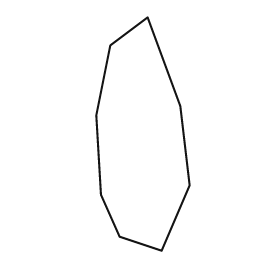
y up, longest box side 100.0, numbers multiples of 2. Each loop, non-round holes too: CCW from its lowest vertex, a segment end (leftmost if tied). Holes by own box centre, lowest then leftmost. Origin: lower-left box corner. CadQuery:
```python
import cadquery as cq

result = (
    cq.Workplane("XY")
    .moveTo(28.0, 0.0)
    .lineTo(40.0, 28.0)
    .lineTo(36.0, 62.0)
    .lineTo(22.0, 100.0)
    .lineTo(6.0, 88.0)
    .lineTo(0.0, 58.0)
    .lineTo(2.0, 24.0)
    .lineTo(10.0, 6.0)
    .close()
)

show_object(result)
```